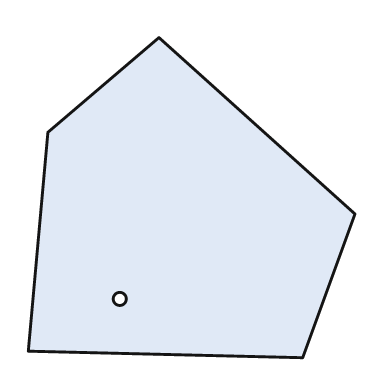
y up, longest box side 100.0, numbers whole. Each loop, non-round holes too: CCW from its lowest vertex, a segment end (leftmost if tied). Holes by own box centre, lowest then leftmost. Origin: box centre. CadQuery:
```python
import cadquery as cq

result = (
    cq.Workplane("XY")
    .moveTo(34.0, -49.0)
    .lineTo(50.0, -5.0)
    .lineTo(-10.0, 49.0)
    .lineTo(-44.0, 20.0)
    .lineTo(-50.0, -47.0)
    .close()
    .moveTo(-22.0, -31.0)
    .circle(2.0)
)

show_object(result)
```